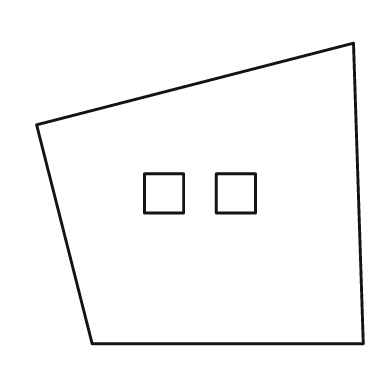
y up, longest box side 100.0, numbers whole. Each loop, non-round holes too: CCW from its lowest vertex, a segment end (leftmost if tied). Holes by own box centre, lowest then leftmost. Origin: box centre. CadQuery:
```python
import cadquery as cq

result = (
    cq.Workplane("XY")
    .moveTo(-33.0, -46.0)
    .lineTo(50.0, -46.0)
    .lineTo(47.0, 46.0)
    .lineTo(-50.0, 21.0)
    .close()
    .moveTo(-17.0, -6.0)
    .lineTo(-5.0, -6.0)
    .lineTo(-5.0, 6.0)
    .lineTo(-17.0, 6.0)
    .close()
    .moveTo(5.0, -6.0)
    .lineTo(17.0, -6.0)
    .lineTo(17.0, 6.0)
    .lineTo(5.0, 6.0)
    .close()
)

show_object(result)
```